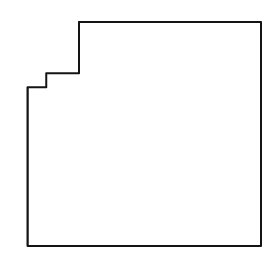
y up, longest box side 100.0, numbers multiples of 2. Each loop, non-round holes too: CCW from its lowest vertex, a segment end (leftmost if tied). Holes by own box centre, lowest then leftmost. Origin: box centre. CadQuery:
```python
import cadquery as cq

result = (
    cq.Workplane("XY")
    .moveTo(-50.0, -48.0)
    .lineTo(50.0, -48.0)
    .lineTo(50.0, 48.0)
    .lineTo(-28.0, 48.0)
    .lineTo(-28.0, 26.0)
    .lineTo(-42.0, 26.0)
    .lineTo(-42.0, 20.0)
    .lineTo(-50.0, 20.0)
    .close()
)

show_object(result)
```